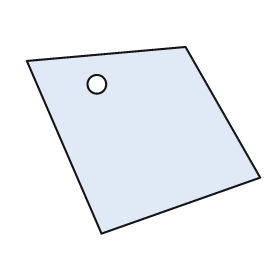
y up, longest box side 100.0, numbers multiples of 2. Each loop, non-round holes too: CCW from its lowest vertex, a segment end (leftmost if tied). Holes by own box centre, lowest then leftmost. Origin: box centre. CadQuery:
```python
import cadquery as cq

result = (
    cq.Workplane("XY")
    .moveTo(-18.0, -40.0)
    .lineTo(50.0, -16.0)
    .lineTo(18.0, 40.0)
    .lineTo(-50.0, 34.0)
    .close()
    .moveTo(-20.0, 24.0)
    .circle(4.0)
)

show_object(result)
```